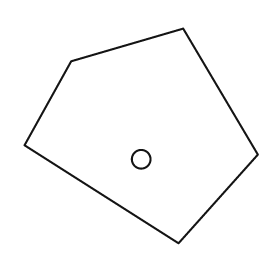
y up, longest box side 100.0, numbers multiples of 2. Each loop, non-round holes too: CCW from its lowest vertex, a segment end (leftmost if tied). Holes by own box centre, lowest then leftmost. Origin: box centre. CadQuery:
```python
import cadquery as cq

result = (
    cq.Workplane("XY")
    .moveTo(16.0, -46.0)
    .lineTo(50.0, -8.0)
    .lineTo(18.0, 46.0)
    .lineTo(-30.0, 32.0)
    .lineTo(-50.0, -4.0)
    .close()
    .moveTo(0.0, -10.0)
    .circle(4.0)
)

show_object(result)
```